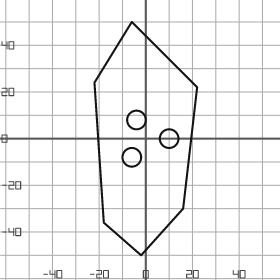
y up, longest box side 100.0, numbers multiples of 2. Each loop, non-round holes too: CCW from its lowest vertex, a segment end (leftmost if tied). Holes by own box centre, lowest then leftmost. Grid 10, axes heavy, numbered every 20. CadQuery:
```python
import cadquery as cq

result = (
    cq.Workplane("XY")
    .moveTo(-2.0, -50.0)
    .lineTo(16.0, -30.0)
    .lineTo(22.0, 22.0)
    .lineTo(-6.0, 50.0)
    .lineTo(-22.0, 24.0)
    .lineTo(-18.0, -36.0)
    .close()
    .moveTo(-6.0, -8.0)
    .circle(4.0)
    .moveTo(10.0, 0.0)
    .circle(4.0)
    .moveTo(-4.0, 8.0)
    .circle(4.0)
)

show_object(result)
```